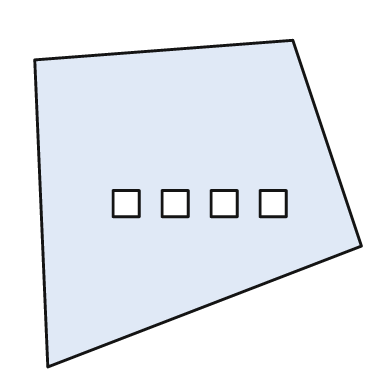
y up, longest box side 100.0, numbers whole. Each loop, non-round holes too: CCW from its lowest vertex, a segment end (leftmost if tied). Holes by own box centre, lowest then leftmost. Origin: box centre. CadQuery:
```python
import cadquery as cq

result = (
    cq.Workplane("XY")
    .moveTo(-46.0, -50.0)
    .lineTo(50.0, -13.0)
    .lineTo(29.0, 50.0)
    .lineTo(-50.0, 44.0)
    .close()
    .moveTo(-26.0, -4.0)
    .lineTo(-18.0, -4.0)
    .lineTo(-18.0, 4.0)
    .lineTo(-26.0, 4.0)
    .close()
    .moveTo(-11.0, -4.0)
    .lineTo(-3.0, -4.0)
    .lineTo(-3.0, 4.0)
    .lineTo(-11.0, 4.0)
    .close()
    .moveTo(4.0, -4.0)
    .lineTo(12.0, -4.0)
    .lineTo(12.0, 4.0)
    .lineTo(4.0, 4.0)
    .close()
    .moveTo(19.0, -4.0)
    .lineTo(27.0, -4.0)
    .lineTo(27.0, 4.0)
    .lineTo(19.0, 4.0)
    .close()
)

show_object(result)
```